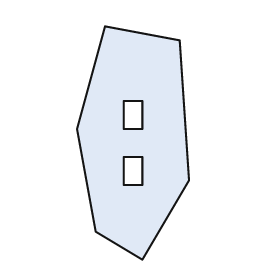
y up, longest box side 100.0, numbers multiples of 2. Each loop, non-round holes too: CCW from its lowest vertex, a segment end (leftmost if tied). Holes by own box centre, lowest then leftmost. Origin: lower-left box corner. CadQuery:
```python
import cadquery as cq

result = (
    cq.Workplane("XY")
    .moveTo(28.0, 0.0)
    .lineTo(48.0, 34.0)
    .lineTo(44.0, 94.0)
    .lineTo(12.0, 100.0)
    .lineTo(0.0, 56.0)
    .lineTo(8.0, 12.0)
    .close()
    .moveTo(20.0, 32.0)
    .lineTo(28.0, 32.0)
    .lineTo(28.0, 44.0)
    .lineTo(20.0, 44.0)
    .close()
    .moveTo(20.0, 56.0)
    .lineTo(28.0, 56.0)
    .lineTo(28.0, 68.0)
    .lineTo(20.0, 68.0)
    .close()
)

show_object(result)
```